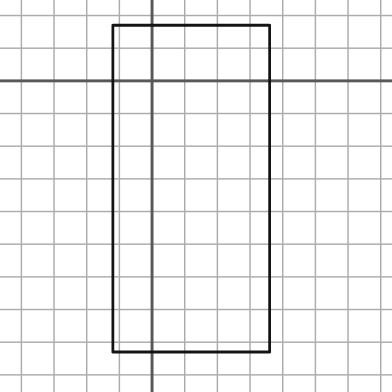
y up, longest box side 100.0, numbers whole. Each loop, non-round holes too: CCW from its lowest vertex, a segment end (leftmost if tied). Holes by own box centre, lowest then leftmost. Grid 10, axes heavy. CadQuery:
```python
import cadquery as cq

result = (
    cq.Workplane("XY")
    .moveTo(-12.0, -83.0)
    .lineTo(36.0, -83.0)
    .lineTo(36.0, 17.0)
    .lineTo(-12.0, 17.0)
    .close()
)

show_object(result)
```